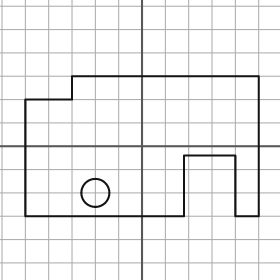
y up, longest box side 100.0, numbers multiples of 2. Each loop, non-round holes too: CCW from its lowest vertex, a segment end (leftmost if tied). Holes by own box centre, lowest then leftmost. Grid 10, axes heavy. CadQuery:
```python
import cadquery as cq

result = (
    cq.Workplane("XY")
    .moveTo(-50.0, -30.0)
    .lineTo(18.0, -30.0)
    .lineTo(18.0, -4.0)
    .lineTo(40.0, -4.0)
    .lineTo(40.0, -30.0)
    .lineTo(50.0, -30.0)
    .lineTo(50.0, 30.0)
    .lineTo(-30.0, 30.0)
    .lineTo(-30.0, 20.0)
    .lineTo(-50.0, 20.0)
    .close()
    .moveTo(-20.0, -20.0)
    .circle(6.0)
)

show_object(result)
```